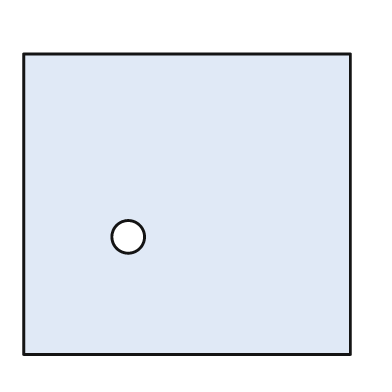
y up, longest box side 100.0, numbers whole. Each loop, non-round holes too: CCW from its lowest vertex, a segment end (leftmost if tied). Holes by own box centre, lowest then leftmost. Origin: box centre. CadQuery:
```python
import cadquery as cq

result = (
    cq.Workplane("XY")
    .moveTo(-50.0, -46.0)
    .lineTo(50.0, -46.0)
    .lineTo(50.0, 46.0)
    .lineTo(-50.0, 46.0)
    .close()
    .moveTo(-18.0, -10.0)
    .circle(5.0)
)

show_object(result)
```